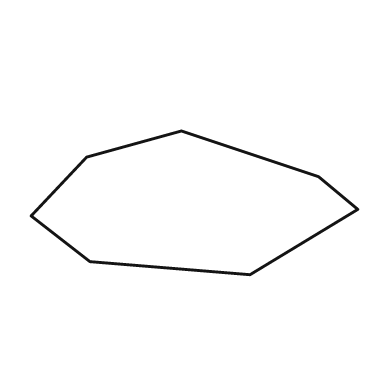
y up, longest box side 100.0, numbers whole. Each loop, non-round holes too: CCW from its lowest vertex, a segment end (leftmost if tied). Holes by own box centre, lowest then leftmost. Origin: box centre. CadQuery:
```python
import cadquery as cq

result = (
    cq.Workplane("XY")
    .moveTo(17.0, -22.0)
    .lineTo(50.0, -2.0)
    .lineTo(38.0, 8.0)
    .lineTo(-4.0, 22.0)
    .lineTo(-33.0, 14.0)
    .lineTo(-50.0, -4.0)
    .lineTo(-32.0, -18.0)
    .close()
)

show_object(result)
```